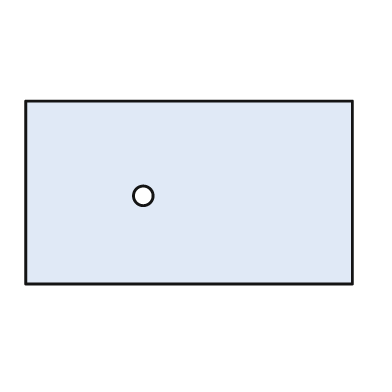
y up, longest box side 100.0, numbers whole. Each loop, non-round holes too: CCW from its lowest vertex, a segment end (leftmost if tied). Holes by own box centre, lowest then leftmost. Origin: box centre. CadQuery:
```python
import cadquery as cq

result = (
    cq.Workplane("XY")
    .moveTo(-50.0, -28.0)
    .lineTo(50.0, -28.0)
    .lineTo(50.0, 28.0)
    .lineTo(-50.0, 28.0)
    .close()
    .moveTo(-14.0, -1.0)
    .circle(3.0)
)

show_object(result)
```